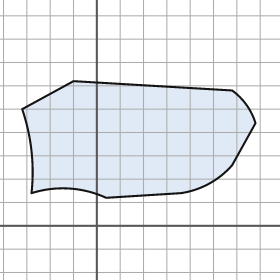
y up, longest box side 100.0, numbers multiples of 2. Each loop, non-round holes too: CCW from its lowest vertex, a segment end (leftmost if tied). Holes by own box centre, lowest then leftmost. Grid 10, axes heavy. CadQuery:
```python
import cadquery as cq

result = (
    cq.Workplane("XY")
    .moveTo(4.0, 12.0)
    .lineTo(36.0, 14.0)
    .threePointArc((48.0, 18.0), (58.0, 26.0))
    .lineTo(68.0, 44.0)
    .threePointArc((64.0, 52.0), (58.0, 58.0))
    .lineTo(-10.0, 62.0)
    .lineTo(-32.0, 50.0)
    .threePointArc((-28.0, 32.0), (-28.0, 14.0))
    .threePointArc((-12.0, 16.0), (4.0, 12.0))
    .close()
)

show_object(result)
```